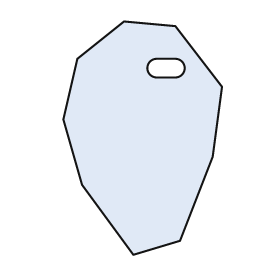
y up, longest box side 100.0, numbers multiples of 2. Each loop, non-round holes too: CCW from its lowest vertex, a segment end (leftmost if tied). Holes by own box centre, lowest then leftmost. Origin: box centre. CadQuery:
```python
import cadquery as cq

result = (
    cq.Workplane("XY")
    .moveTo(-4.0, -50.0)
    .lineTo(16.0, -44.0)
    .lineTo(30.0, -8.0)
    .lineTo(34.0, 22.0)
    .lineTo(14.0, 48.0)
    .lineTo(-8.0, 50.0)
    .lineTo(-28.0, 34.0)
    .lineTo(-34.0, 8.0)
    .lineTo(-26.0, -20.0)
    .close()
    .moveTo(6.0, 26.0)
    .lineTo(14.0, 26.0)
    .threePointArc((18.0, 30.0), (14.0, 34.0))
    .lineTo(6.0, 34.0)
    .threePointArc((2.0, 30.0), (6.0, 26.0))
    .close()
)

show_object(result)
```